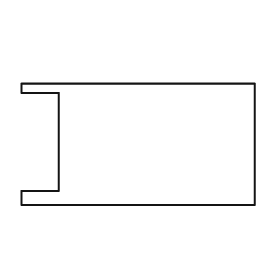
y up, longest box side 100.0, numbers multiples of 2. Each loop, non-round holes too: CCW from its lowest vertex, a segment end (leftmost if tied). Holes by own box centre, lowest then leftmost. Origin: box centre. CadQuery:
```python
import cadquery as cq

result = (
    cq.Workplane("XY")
    .moveTo(-50.0, -26.0)
    .lineTo(50.0, -26.0)
    .lineTo(50.0, 26.0)
    .lineTo(-50.0, 26.0)
    .lineTo(-50.0, 22.0)
    .lineTo(-34.0, 22.0)
    .lineTo(-34.0, -20.0)
    .lineTo(-50.0, -20.0)
    .close()
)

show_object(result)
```